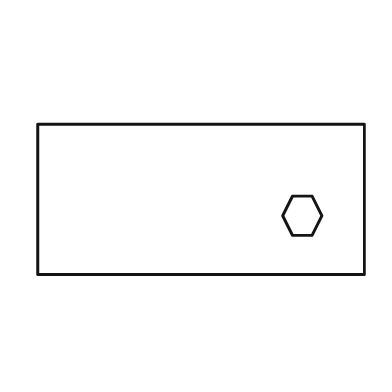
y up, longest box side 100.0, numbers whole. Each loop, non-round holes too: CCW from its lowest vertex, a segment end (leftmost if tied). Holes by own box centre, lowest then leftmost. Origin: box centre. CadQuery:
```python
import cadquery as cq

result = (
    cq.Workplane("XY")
    .moveTo(-50.0, -23.0)
    .lineTo(50.0, -23.0)
    .lineTo(50.0, 23.0)
    .lineTo(-50.0, 23.0)
    .close()
    .moveTo(28.0, -11.0)
    .lineTo(34.0, -11.0)
    .lineTo(37.0, -5.0)
    .lineTo(34.0, 1.0)
    .lineTo(28.0, 1.0)
    .lineTo(25.0, -5.0)
    .close()
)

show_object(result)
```